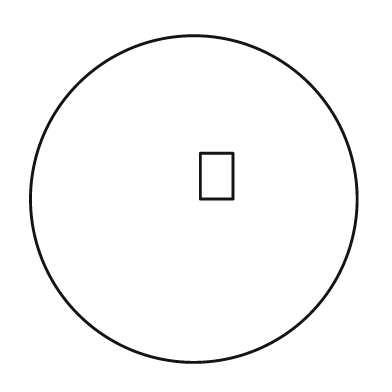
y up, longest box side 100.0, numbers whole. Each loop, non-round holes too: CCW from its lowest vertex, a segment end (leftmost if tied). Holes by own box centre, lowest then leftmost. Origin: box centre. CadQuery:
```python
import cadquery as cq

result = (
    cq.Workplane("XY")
    .moveTo(0.0, 0.0)
    .circle(50.0)
    .moveTo(2.0, 0.0)
    .lineTo(12.0, 0.0)
    .lineTo(12.0, 14.0)
    .lineTo(2.0, 14.0)
    .close()
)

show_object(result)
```